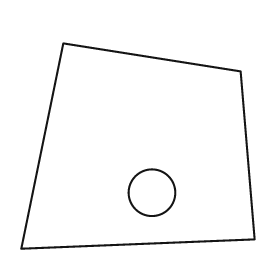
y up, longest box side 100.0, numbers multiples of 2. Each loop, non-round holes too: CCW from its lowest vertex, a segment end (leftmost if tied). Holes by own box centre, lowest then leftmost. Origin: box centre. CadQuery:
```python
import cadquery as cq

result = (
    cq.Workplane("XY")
    .moveTo(-50.0, -44.0)
    .lineTo(50.0, -40.0)
    .lineTo(44.0, 32.0)
    .lineTo(-32.0, 44.0)
    .close()
    .moveTo(6.0, -20.0)
    .circle(10.0)
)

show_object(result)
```